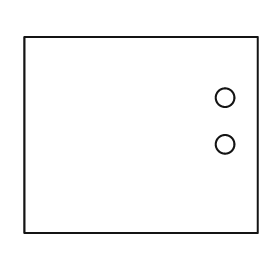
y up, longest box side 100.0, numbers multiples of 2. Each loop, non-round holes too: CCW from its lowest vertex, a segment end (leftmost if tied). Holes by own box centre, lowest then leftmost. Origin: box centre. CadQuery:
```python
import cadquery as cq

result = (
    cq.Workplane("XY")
    .moveTo(-50.0, -42.0)
    .lineTo(50.0, -42.0)
    .lineTo(50.0, 42.0)
    .lineTo(-50.0, 42.0)
    .close()
    .moveTo(36.0, -4.0)
    .circle(4.0)
    .moveTo(36.0, 16.0)
    .circle(4.0)
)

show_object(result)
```